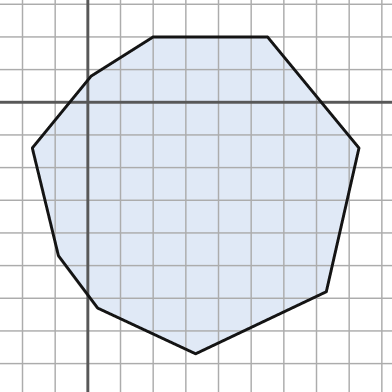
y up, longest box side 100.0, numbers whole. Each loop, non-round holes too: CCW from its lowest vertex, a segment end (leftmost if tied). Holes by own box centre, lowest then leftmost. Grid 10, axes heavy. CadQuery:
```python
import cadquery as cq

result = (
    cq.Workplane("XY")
    .moveTo(33.0, -77.0)
    .lineTo(73.0, -58.0)
    .lineTo(83.0, -14.0)
    .lineTo(55.0, 20.0)
    .lineTo(20.0, 20.0)
    .lineTo(1.0, 8.0)
    .lineTo(-17.0, -14.0)
    .lineTo(-9.0, -47.0)
    .lineTo(3.0, -63.0)
    .close()
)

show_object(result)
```